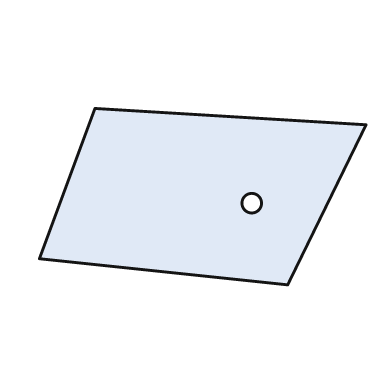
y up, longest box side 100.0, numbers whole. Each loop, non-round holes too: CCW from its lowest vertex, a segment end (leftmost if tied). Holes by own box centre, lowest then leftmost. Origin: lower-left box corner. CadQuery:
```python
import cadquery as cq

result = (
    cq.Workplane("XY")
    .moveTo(76.0, 0.0)
    .lineTo(100.0, 49.0)
    .lineTo(17.0, 54.0)
    .lineTo(0.0, 8.0)
    .close()
    .moveTo(65.0, 25.0)
    .circle(3.0)
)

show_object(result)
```